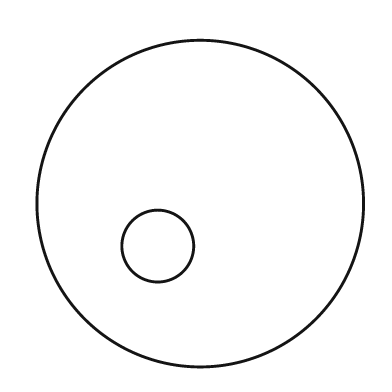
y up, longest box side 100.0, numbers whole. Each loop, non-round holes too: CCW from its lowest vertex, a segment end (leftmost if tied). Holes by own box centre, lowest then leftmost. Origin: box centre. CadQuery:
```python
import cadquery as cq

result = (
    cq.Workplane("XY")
    .moveTo(0.0, 0.0)
    .circle(50.0)
    .moveTo(-13.0, -13.0)
    .circle(11.0)
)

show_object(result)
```